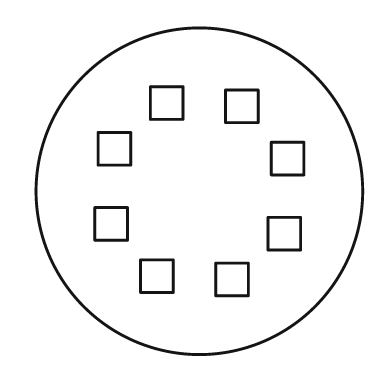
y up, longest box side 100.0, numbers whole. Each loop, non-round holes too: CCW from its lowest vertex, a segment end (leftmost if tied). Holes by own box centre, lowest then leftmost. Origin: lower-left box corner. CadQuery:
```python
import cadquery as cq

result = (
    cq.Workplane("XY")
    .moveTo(50.0, 50.0)
    .circle(50.0)
    .moveTo(55.0, 18.0)
    .lineTo(65.0, 18.0)
    .lineTo(65.0, 28.0)
    .lineTo(55.0, 28.0)
    .close()
    .moveTo(32.0, 19.0)
    .lineTo(42.0, 19.0)
    .lineTo(42.0, 29.0)
    .lineTo(32.0, 29.0)
    .close()
    .moveTo(71.0, 32.0)
    .lineTo(81.0, 32.0)
    .lineTo(81.0, 42.0)
    .lineTo(71.0, 42.0)
    .close()
    .moveTo(18.0, 35.0)
    .lineTo(28.0, 35.0)
    .lineTo(28.0, 45.0)
    .lineTo(18.0, 45.0)
    .close()
    .moveTo(72.0, 55.0)
    .lineTo(82.0, 55.0)
    .lineTo(82.0, 65.0)
    .lineTo(72.0, 65.0)
    .close()
    .moveTo(19.0, 58.0)
    .lineTo(29.0, 58.0)
    .lineTo(29.0, 68.0)
    .lineTo(19.0, 68.0)
    .close()
    .moveTo(58.0, 71.0)
    .lineTo(68.0, 71.0)
    .lineTo(68.0, 81.0)
    .lineTo(58.0, 81.0)
    .close()
    .moveTo(35.0, 72.0)
    .lineTo(45.0, 72.0)
    .lineTo(45.0, 82.0)
    .lineTo(35.0, 82.0)
    .close()
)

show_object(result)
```